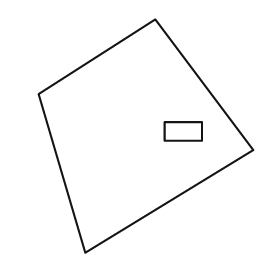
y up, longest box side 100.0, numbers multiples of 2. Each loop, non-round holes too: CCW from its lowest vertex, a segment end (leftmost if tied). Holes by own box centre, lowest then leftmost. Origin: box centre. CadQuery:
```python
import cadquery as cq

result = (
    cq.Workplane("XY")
    .moveTo(-26.0, -50.0)
    .lineTo(46.0, -6.0)
    .lineTo(4.0, 50.0)
    .lineTo(-46.0, 18.0)
    .close()
    .moveTo(8.0, -2.0)
    .lineTo(24.0, -2.0)
    .lineTo(24.0, 6.0)
    .lineTo(8.0, 6.0)
    .close()
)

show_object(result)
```